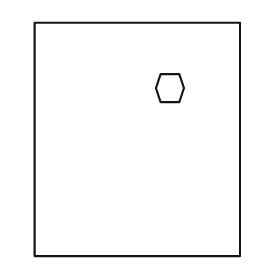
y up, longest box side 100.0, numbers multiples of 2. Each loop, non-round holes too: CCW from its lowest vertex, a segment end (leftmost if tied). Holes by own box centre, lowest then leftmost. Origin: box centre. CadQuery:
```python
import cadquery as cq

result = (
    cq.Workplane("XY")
    .moveTo(-44.0, -50.0)
    .lineTo(44.0, -50.0)
    .lineTo(44.0, 50.0)
    .lineTo(-44.0, 50.0)
    .close()
    .moveTo(10.0, 16.0)
    .lineTo(18.0, 16.0)
    .lineTo(20.0, 22.0)
    .lineTo(18.0, 28.0)
    .lineTo(10.0, 28.0)
    .lineTo(8.0, 22.0)
    .close()
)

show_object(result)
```